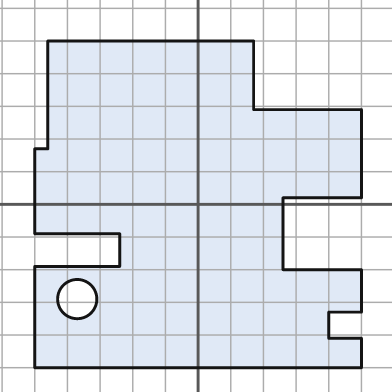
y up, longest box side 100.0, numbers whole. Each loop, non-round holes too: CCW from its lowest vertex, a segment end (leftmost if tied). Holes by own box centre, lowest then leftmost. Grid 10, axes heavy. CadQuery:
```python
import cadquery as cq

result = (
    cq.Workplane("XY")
    .moveTo(-50.0, -50.0)
    .lineTo(50.0, -50.0)
    .lineTo(50.0, -41.0)
    .lineTo(40.0, -41.0)
    .lineTo(40.0, -33.0)
    .lineTo(50.0, -33.0)
    .lineTo(50.0, -20.0)
    .lineTo(26.0, -20.0)
    .lineTo(26.0, 2.0)
    .lineTo(50.0, 2.0)
    .lineTo(50.0, 29.0)
    .lineTo(17.0, 29.0)
    .lineTo(17.0, 50.0)
    .lineTo(-46.0, 50.0)
    .lineTo(-46.0, 17.0)
    .lineTo(-50.0, 17.0)
    .lineTo(-50.0, -9.0)
    .lineTo(-24.0, -9.0)
    .lineTo(-24.0, -19.0)
    .lineTo(-50.0, -19.0)
    .close()
    .moveTo(-37.0, -29.0)
    .circle(6.0)
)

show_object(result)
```